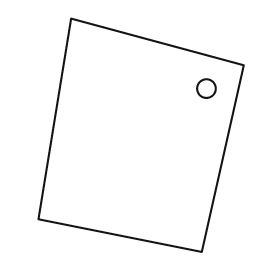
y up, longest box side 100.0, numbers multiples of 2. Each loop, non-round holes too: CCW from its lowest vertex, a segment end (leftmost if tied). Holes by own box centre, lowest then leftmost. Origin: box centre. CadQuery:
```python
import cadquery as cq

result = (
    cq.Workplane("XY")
    .moveTo(26.0, -50.0)
    .lineTo(44.0, 30.0)
    .lineTo(-30.0, 50.0)
    .lineTo(-44.0, -36.0)
    .close()
    .moveTo(28.0, 20.0)
    .circle(4.0)
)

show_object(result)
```